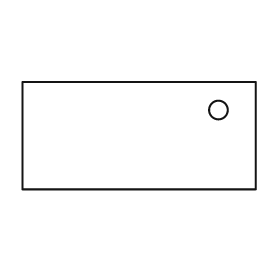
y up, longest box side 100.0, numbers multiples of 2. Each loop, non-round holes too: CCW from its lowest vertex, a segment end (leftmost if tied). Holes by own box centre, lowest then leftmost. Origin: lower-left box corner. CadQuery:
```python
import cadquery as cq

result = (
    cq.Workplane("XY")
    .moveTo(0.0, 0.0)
    .lineTo(100.0, 0.0)
    .lineTo(100.0, 46.0)
    .lineTo(0.0, 46.0)
    .close()
    .moveTo(84.0, 34.0)
    .circle(4.0)
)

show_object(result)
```